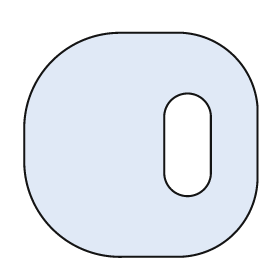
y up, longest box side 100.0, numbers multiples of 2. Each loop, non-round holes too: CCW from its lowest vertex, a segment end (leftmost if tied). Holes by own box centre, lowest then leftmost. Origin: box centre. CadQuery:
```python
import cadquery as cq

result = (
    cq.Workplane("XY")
    .moveTo(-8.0, -48.0)
    .lineTo(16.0, -48.0)
    .threePointArc((40.0, -38.0), (50.0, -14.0))
    .lineTo(50.0, 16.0)
    .threePointArc((40.0, 38.0), (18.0, 48.0))
    .lineTo(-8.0, 48.0)
    .threePointArc((-38.0, 36.0), (-50.0, 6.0))
    .lineTo(-50.0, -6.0)
    .threePointArc((-38.0, -36.0), (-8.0, -48.0))
    .close()
    .moveTo(10.0, -12.0)
    .threePointArc((20.0, -22.0), (30.0, -12.0))
    .lineTo(30.0, 12.0)
    .threePointArc((20.0, 22.0), (10.0, 12.0))
    .close()
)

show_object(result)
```